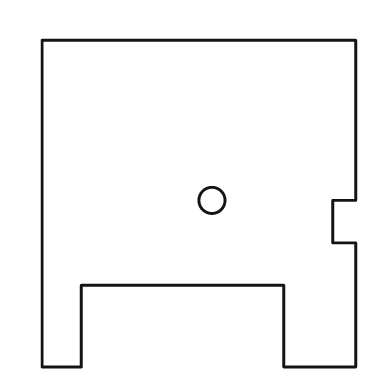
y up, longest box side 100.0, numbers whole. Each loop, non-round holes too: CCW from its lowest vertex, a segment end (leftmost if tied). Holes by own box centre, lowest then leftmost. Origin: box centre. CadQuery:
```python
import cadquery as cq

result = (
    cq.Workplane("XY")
    .moveTo(-48.0, -50.0)
    .lineTo(-36.0, -50.0)
    .lineTo(-36.0, -25.0)
    .lineTo(26.0, -25.0)
    .lineTo(26.0, -50.0)
    .lineTo(48.0, -50.0)
    .lineTo(48.0, -12.0)
    .lineTo(41.0, -12.0)
    .lineTo(41.0, 1.0)
    .lineTo(48.0, 1.0)
    .lineTo(48.0, 50.0)
    .lineTo(-48.0, 50.0)
    .close()
    .moveTo(4.0, 1.0)
    .circle(4.0)
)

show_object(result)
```